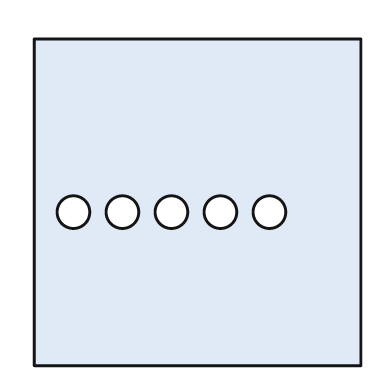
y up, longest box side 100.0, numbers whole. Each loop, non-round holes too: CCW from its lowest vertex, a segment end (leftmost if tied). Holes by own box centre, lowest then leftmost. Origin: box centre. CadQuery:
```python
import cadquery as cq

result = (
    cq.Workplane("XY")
    .moveTo(-50.0, -50.0)
    .lineTo(50.0, -50.0)
    .lineTo(50.0, 50.0)
    .lineTo(-50.0, 50.0)
    .close()
    .moveTo(-38.0, -3.0)
    .circle(5.0)
    .moveTo(-23.0, -3.0)
    .circle(5.0)
    .moveTo(-8.0, -3.0)
    .circle(5.0)
    .moveTo(7.0, -3.0)
    .circle(5.0)
    .moveTo(22.0, -3.0)
    .circle(5.0)
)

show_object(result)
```